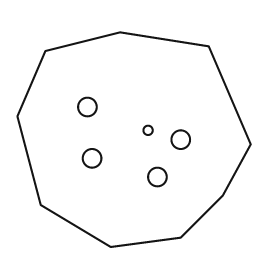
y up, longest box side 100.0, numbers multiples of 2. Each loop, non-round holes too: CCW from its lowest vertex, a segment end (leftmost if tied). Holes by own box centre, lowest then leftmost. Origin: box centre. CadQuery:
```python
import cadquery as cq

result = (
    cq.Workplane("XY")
    .moveTo(-10.0, -46.0)
    .lineTo(20.0, -42.0)
    .lineTo(38.0, -24.0)
    .lineTo(50.0, -2.0)
    .lineTo(32.0, 40.0)
    .lineTo(-6.0, 46.0)
    .lineTo(-38.0, 38.0)
    .lineTo(-50.0, 10.0)
    .lineTo(-40.0, -28.0)
    .close()
    .moveTo(10.0, -16.0)
    .circle(4.0)
    .moveTo(-18.0, -8.0)
    .circle(4.0)
    .moveTo(20.0, 0.0)
    .circle(4.0)
    .moveTo(6.0, 4.0)
    .circle(2.0)
    .moveTo(-20.0, 14.0)
    .circle(4.0)
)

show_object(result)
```